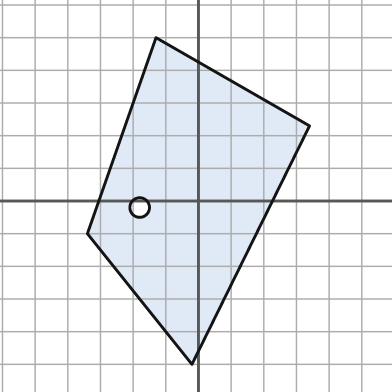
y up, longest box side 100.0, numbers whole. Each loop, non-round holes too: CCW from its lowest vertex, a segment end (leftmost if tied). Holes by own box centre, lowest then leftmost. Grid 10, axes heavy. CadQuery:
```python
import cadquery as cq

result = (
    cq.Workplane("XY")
    .moveTo(-2.0, -50.0)
    .lineTo(34.0, 23.0)
    .lineTo(-13.0, 50.0)
    .lineTo(-34.0, -10.0)
    .close()
    .moveTo(-18.0, -2.0)
    .circle(3.0)
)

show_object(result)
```